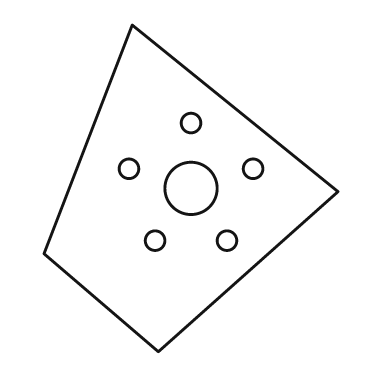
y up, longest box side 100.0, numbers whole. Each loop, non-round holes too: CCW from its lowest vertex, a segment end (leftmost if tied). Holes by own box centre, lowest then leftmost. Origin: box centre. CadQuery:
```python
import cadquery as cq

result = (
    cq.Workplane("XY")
    .moveTo(-10.0, -50.0)
    .lineTo(45.0, -1.0)
    .lineTo(-18.0, 50.0)
    .lineTo(-45.0, -20.0)
    .close()
    .moveTo(-11.0, -16.0)
    .circle(3.0)
    .moveTo(11.0, -16.0)
    .circle(3.0)
    .moveTo(0.0, 0.0)
    .circle(8.0)
    .moveTo(-19.0, 6.0)
    .circle(3.0)
    .moveTo(19.0, 6.0)
    .circle(3.0)
    .moveTo(0.0, 20.0)
    .circle(3.0)
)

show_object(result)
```